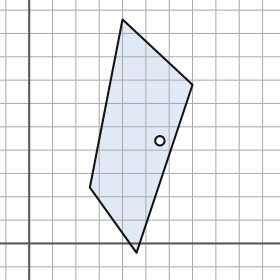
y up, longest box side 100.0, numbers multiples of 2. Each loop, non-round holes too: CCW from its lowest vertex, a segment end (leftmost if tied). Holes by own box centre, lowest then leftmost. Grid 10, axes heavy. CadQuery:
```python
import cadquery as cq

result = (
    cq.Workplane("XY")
    .moveTo(46.0, -4.0)
    .lineTo(70.0, 68.0)
    .lineTo(40.0, 96.0)
    .lineTo(26.0, 24.0)
    .close()
    .moveTo(56.0, 44.0)
    .circle(2.0)
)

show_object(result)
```